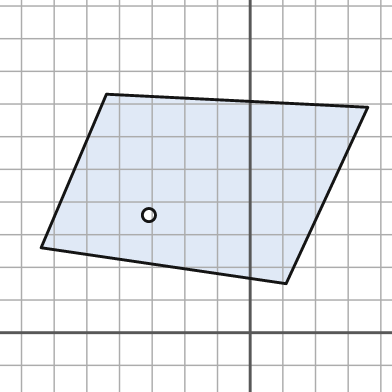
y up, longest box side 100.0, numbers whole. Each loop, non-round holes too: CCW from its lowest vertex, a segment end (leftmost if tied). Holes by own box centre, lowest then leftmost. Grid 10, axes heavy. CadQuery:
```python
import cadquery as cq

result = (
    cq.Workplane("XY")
    .moveTo(11.0, 15.0)
    .lineTo(36.0, 69.0)
    .lineTo(-44.0, 73.0)
    .lineTo(-64.0, 26.0)
    .close()
    .moveTo(-31.0, 36.0)
    .circle(2.0)
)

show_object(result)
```